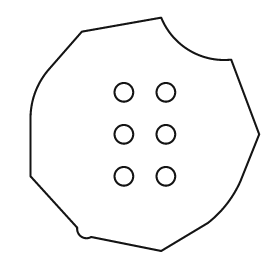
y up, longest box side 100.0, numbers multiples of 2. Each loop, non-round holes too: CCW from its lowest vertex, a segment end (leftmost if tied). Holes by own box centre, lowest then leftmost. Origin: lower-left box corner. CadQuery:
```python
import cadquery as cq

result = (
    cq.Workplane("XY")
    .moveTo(56.0, 0.0)
    .lineTo(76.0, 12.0)
    .threePointArc((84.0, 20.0), (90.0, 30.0))
    .lineTo(98.0, 50.0)
    .lineTo(86.0, 82.0)
    .threePointArc((68.0, 86.0), (56.0, 100.0))
    .lineTo(22.0, 94.0)
    .lineTo(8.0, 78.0)
    .threePointArc((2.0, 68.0), (0.0, 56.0))
    .lineTo(0.0, 32.0)
    .lineTo(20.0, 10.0)
    .threePointArc((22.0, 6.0), (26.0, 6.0))
    .close()
    .moveTo(40.0, 32.0)
    .circle(4.0)
    .moveTo(58.0, 32.0)
    .circle(4.0)
    .moveTo(40.0, 50.0)
    .circle(4.0)
    .moveTo(58.0, 50.0)
    .circle(4.0)
    .moveTo(40.0, 68.0)
    .circle(4.0)
    .moveTo(58.0, 68.0)
    .circle(4.0)
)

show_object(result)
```